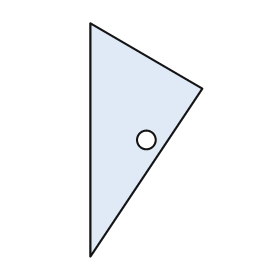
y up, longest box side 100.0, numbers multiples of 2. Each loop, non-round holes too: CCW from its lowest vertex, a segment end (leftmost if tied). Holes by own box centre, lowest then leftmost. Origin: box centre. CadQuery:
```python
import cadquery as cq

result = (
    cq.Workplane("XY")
    .moveTo(-24.0, -50.0)
    .lineTo(24.0, 22.0)
    .lineTo(-24.0, 50.0)
    .close()
    .moveTo(0.0, 0.0)
    .circle(4.0)
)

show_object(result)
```